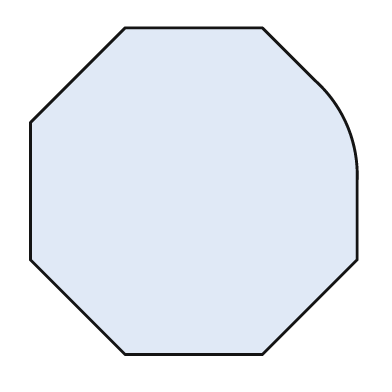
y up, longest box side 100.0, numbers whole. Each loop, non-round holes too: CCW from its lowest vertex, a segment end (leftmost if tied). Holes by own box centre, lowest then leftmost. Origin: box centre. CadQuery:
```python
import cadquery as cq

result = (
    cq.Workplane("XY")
    .moveTo(-21.0, -50.0)
    .lineTo(21.0, -50.0)
    .lineTo(50.0, -21.0)
    .lineTo(50.0, 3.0)
    .threePointArc((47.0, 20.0), (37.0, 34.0))
    .lineTo(21.0, 50.0)
    .lineTo(-21.0, 50.0)
    .lineTo(-50.0, 21.0)
    .lineTo(-50.0, -21.0)
    .close()
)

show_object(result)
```